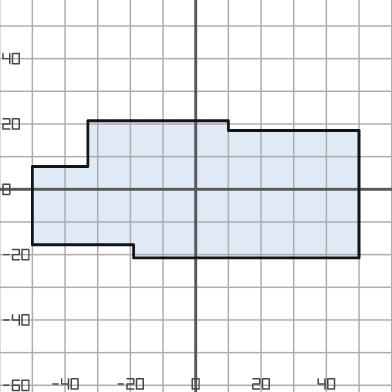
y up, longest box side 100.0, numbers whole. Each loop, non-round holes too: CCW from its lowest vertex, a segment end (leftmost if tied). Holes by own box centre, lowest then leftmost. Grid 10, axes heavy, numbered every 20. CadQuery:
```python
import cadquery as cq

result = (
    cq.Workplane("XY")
    .moveTo(-19.0, -21.0)
    .lineTo(50.0, -21.0)
    .lineTo(50.0, 18.0)
    .lineTo(10.0, 18.0)
    .lineTo(10.0, 21.0)
    .lineTo(-33.0, 21.0)
    .lineTo(-33.0, 7.0)
    .lineTo(-50.0, 7.0)
    .lineTo(-50.0, -17.0)
    .lineTo(-19.0, -17.0)
    .close()
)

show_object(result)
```